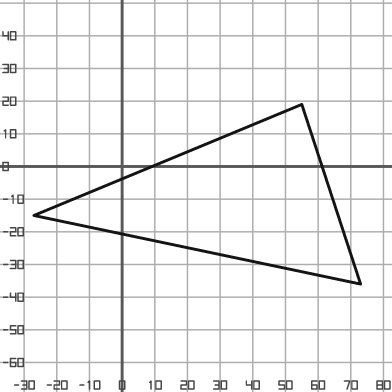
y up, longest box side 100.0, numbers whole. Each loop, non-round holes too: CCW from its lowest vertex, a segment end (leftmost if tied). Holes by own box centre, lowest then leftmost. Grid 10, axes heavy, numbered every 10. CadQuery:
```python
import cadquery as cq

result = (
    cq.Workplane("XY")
    .moveTo(73.0, -36.0)
    .lineTo(55.0, 19.0)
    .lineTo(-27.0, -15.0)
    .close()
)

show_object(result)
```